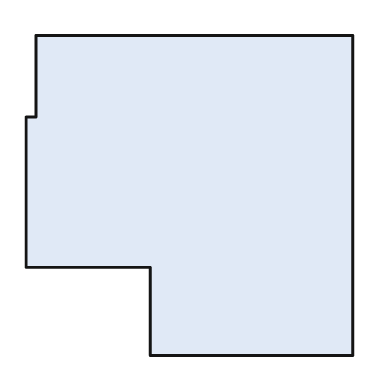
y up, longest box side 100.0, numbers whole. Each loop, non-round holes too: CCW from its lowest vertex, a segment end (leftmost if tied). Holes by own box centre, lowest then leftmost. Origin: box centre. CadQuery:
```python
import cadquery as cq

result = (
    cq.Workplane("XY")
    .moveTo(-12.0, -49.0)
    .lineTo(50.0, -49.0)
    .lineTo(50.0, 49.0)
    .lineTo(-47.0, 49.0)
    .lineTo(-47.0, 24.0)
    .lineTo(-50.0, 24.0)
    .lineTo(-50.0, -22.0)
    .lineTo(-12.0, -22.0)
    .close()
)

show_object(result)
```